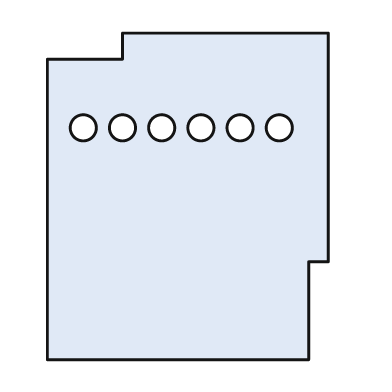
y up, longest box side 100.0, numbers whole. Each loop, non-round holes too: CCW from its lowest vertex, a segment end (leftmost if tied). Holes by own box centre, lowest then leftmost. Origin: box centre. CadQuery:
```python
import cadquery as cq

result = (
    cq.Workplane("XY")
    .moveTo(-43.0, -50.0)
    .lineTo(37.0, -50.0)
    .lineTo(37.0, -20.0)
    .lineTo(43.0, -20.0)
    .lineTo(43.0, 50.0)
    .lineTo(-20.0, 50.0)
    .lineTo(-20.0, 42.0)
    .lineTo(-43.0, 42.0)
    .close()
    .moveTo(-32.0, 21.0)
    .circle(4.0)
    .moveTo(-20.0, 21.0)
    .circle(4.0)
    .moveTo(-8.0, 21.0)
    .circle(4.0)
    .moveTo(4.0, 21.0)
    .circle(4.0)
    .moveTo(16.0, 21.0)
    .circle(4.0)
    .moveTo(28.0, 21.0)
    .circle(4.0)
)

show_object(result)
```